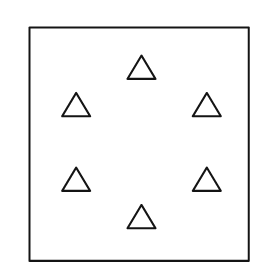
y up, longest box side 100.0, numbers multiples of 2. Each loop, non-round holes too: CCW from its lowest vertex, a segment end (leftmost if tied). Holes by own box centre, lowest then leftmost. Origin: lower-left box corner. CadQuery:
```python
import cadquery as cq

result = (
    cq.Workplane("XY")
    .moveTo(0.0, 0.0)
    .lineTo(94.0, 0.0)
    .lineTo(94.0, 100.0)
    .lineTo(0.0, 100.0)
    .close()
    .moveTo(42.0, 14.0)
    .lineTo(54.0, 14.0)
    .lineTo(48.0, 24.0)
    .close()
    .moveTo(14.0, 30.0)
    .lineTo(26.0, 30.0)
    .lineTo(20.0, 40.0)
    .close()
    .moveTo(70.0, 30.0)
    .lineTo(82.0, 30.0)
    .lineTo(76.0, 40.0)
    .close()
    .moveTo(14.0, 62.0)
    .lineTo(26.0, 62.0)
    .lineTo(20.0, 72.0)
    .close()
    .moveTo(70.0, 62.0)
    .lineTo(82.0, 62.0)
    .lineTo(76.0, 72.0)
    .close()
    .moveTo(42.0, 78.0)
    .lineTo(54.0, 78.0)
    .lineTo(48.0, 88.0)
    .close()
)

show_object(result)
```